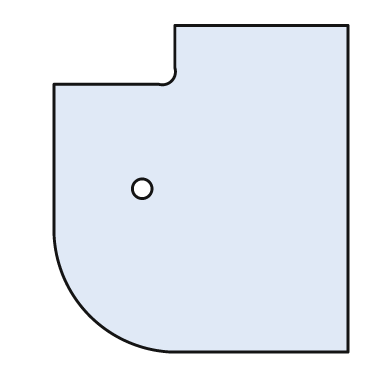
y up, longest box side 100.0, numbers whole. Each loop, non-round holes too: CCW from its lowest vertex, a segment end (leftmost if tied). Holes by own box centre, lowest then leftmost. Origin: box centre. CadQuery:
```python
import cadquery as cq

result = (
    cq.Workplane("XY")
    .moveTo(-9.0, -50.0)
    .lineTo(45.0, -50.0)
    .lineTo(45.0, 50.0)
    .lineTo(-8.0, 50.0)
    .lineTo(-8.0, 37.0)
    .threePointArc((-9.0, 33.0), (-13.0, 32.0))
    .lineTo(-45.0, 32.0)
    .lineTo(-45.0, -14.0)
    .threePointArc((-34.0, -39.0), (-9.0, -50.0))
    .close()
    .moveTo(-18.0, 0.0)
    .circle(3.0)
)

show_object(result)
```